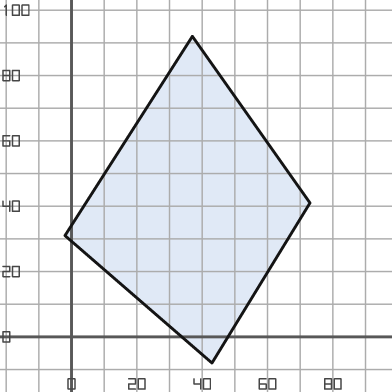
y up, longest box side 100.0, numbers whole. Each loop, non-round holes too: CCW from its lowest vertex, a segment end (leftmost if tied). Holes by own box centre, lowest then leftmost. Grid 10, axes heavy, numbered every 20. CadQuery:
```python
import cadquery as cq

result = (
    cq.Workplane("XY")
    .moveTo(43.0, -8.0)
    .lineTo(73.0, 41.0)
    .lineTo(37.0, 92.0)
    .lineTo(-2.0, 31.0)
    .close()
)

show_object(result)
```